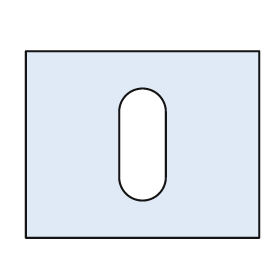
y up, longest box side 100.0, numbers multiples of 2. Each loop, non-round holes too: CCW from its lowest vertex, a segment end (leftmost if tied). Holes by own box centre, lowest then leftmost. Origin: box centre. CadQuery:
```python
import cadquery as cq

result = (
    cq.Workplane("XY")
    .moveTo(-50.0, -40.0)
    .lineTo(50.0, -40.0)
    .lineTo(50.0, 40.0)
    .lineTo(-50.0, 40.0)
    .close()
    .moveTo(-10.0, -14.0)
    .threePointArc((0.0, -24.0), (10.0, -14.0))
    .lineTo(10.0, 14.0)
    .threePointArc((0.0, 24.0), (-10.0, 14.0))
    .close()
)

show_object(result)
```